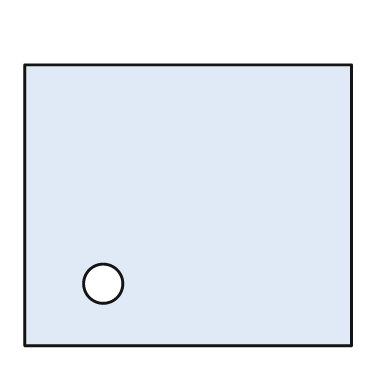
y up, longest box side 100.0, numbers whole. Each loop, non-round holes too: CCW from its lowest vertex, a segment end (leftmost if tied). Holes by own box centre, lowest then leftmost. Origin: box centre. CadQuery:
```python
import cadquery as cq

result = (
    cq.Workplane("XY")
    .moveTo(-50.0, -43.0)
    .lineTo(50.0, -43.0)
    .lineTo(50.0, 43.0)
    .lineTo(-50.0, 43.0)
    .close()
    .moveTo(-26.0, -24.0)
    .circle(6.0)
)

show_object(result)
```